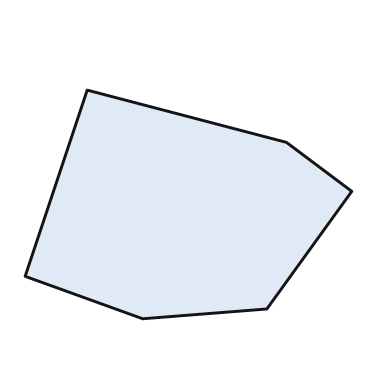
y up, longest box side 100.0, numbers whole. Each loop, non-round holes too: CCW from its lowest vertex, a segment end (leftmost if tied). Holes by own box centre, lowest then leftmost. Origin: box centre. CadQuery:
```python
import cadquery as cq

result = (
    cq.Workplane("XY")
    .moveTo(-14.0, -35.0)
    .lineTo(24.0, -32.0)
    .lineTo(50.0, 4.0)
    .lineTo(30.0, 19.0)
    .lineTo(-31.0, 35.0)
    .lineTo(-50.0, -22.0)
    .close()
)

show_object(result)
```